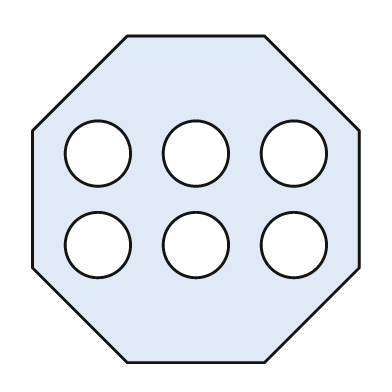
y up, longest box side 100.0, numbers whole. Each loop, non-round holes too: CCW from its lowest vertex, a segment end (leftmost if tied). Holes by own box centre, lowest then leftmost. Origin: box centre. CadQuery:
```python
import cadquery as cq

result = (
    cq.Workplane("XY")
    .moveTo(-21.0, -50.0)
    .lineTo(21.0, -50.0)
    .lineTo(50.0, -21.0)
    .lineTo(50.0, 21.0)
    .lineTo(21.0, 50.0)
    .lineTo(-21.0, 50.0)
    .lineTo(-50.0, 21.0)
    .lineTo(-50.0, -21.0)
    .close()
    .moveTo(-30.0, -14.0)
    .circle(10.0)
    .moveTo(0.0, -14.0)
    .circle(10.0)
    .moveTo(30.0, -14.0)
    .circle(10.0)
    .moveTo(-30.0, 14.0)
    .circle(10.0)
    .moveTo(0.0, 14.0)
    .circle(10.0)
    .moveTo(30.0, 14.0)
    .circle(10.0)
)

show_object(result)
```